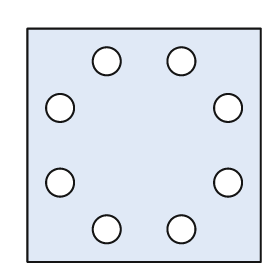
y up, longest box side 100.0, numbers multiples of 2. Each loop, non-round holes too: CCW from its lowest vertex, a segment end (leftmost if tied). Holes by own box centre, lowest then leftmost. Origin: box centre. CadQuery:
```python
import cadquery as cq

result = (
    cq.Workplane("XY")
    .moveTo(-50.0, -50.0)
    .lineTo(50.0, -50.0)
    .lineTo(50.0, 50.0)
    .lineTo(-50.0, 50.0)
    .close()
    .moveTo(-16.0, -36.0)
    .circle(6.0)
    .moveTo(16.0, -36.0)
    .circle(6.0)
    .moveTo(-36.0, -16.0)
    .circle(6.0)
    .moveTo(36.0, -16.0)
    .circle(6.0)
    .moveTo(-36.0, 16.0)
    .circle(6.0)
    .moveTo(36.0, 16.0)
    .circle(6.0)
    .moveTo(-16.0, 36.0)
    .circle(6.0)
    .moveTo(16.0, 36.0)
    .circle(6.0)
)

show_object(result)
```